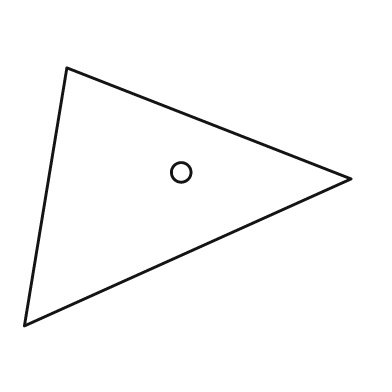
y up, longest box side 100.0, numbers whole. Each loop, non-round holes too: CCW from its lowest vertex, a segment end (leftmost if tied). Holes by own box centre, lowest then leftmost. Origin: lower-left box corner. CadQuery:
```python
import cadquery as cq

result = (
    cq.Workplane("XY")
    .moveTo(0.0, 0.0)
    .lineTo(100.0, 45.0)
    .lineTo(13.0, 79.0)
    .close()
    .moveTo(48.0, 47.0)
    .circle(3.0)
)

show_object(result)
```